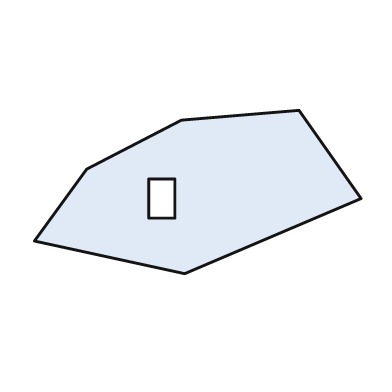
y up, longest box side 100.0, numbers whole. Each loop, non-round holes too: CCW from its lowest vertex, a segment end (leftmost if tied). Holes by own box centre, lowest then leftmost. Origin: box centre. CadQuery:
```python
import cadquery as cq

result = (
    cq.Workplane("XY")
    .moveTo(-4.0, -25.0)
    .lineTo(50.0, -2.0)
    .lineTo(31.0, 25.0)
    .lineTo(-5.0, 22.0)
    .lineTo(-34.0, 7.0)
    .lineTo(-50.0, -15.0)
    .close()
    .moveTo(-15.0, -8.0)
    .lineTo(-7.0, -8.0)
    .lineTo(-7.0, 4.0)
    .lineTo(-15.0, 4.0)
    .close()
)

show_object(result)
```